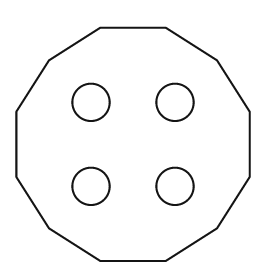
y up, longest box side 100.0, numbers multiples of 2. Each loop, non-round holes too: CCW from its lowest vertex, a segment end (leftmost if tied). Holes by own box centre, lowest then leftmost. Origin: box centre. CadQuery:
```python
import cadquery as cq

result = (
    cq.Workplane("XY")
    .moveTo(-14.0, -50.0)
    .lineTo(14.0, -50.0)
    .lineTo(36.0, -36.0)
    .lineTo(50.0, -14.0)
    .lineTo(50.0, 14.0)
    .lineTo(36.0, 36.0)
    .lineTo(14.0, 50.0)
    .lineTo(-14.0, 50.0)
    .lineTo(-36.0, 36.0)
    .lineTo(-50.0, 14.0)
    .lineTo(-50.0, -14.0)
    .lineTo(-36.0, -36.0)
    .close()
    .moveTo(-18.0, -18.0)
    .circle(8.0)
    .moveTo(18.0, -18.0)
    .circle(8.0)
    .moveTo(-18.0, 18.0)
    .circle(8.0)
    .moveTo(18.0, 18.0)
    .circle(8.0)
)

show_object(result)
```